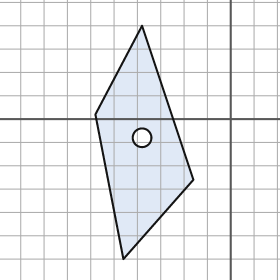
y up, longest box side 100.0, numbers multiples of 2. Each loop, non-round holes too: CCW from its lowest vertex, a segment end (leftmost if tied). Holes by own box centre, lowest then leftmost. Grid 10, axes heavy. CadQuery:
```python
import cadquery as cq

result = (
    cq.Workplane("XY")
    .moveTo(-46.0, -60.0)
    .lineTo(-16.0, -26.0)
    .lineTo(-38.0, 40.0)
    .lineTo(-58.0, 2.0)
    .close()
    .moveTo(-38.0, -8.0)
    .circle(4.0)
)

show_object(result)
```